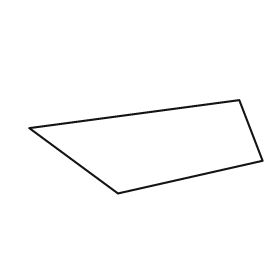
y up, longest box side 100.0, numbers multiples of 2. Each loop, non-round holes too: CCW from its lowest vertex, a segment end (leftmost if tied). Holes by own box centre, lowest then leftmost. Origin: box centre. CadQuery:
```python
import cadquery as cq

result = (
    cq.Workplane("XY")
    .moveTo(-12.0, -20.0)
    .lineTo(50.0, -6.0)
    .lineTo(40.0, 20.0)
    .lineTo(-50.0, 8.0)
    .close()
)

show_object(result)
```